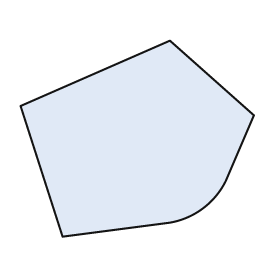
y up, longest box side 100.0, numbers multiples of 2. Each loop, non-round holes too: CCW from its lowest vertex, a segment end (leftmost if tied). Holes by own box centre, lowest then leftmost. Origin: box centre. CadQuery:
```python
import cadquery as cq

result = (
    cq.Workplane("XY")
    .moveTo(-32.0, -42.0)
    .lineTo(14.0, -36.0)
    .threePointArc((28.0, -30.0), (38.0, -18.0))
    .lineTo(50.0, 10.0)
    .lineTo(14.0, 42.0)
    .lineTo(-50.0, 14.0)
    .close()
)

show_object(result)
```